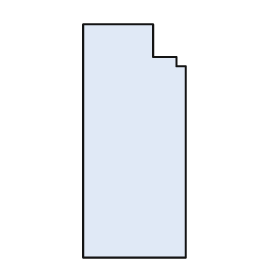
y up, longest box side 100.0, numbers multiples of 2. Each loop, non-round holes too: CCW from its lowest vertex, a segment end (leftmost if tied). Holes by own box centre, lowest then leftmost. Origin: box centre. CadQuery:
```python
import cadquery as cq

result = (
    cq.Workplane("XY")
    .moveTo(-22.0, -50.0)
    .lineTo(22.0, -50.0)
    .lineTo(22.0, 32.0)
    .lineTo(18.0, 32.0)
    .lineTo(18.0, 36.0)
    .lineTo(8.0, 36.0)
    .lineTo(8.0, 50.0)
    .lineTo(-22.0, 50.0)
    .close()
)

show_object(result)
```